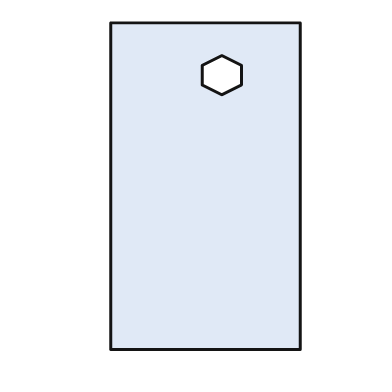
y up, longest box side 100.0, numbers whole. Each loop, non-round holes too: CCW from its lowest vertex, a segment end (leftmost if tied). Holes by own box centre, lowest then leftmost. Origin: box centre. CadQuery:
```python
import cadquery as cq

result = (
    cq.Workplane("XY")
    .moveTo(-29.0, -50.0)
    .lineTo(29.0, -50.0)
    .lineTo(29.0, 50.0)
    .lineTo(-29.0, 50.0)
    .close()
    .moveTo(5.0, 28.0)
    .lineTo(11.0, 31.0)
    .lineTo(11.0, 37.0)
    .lineTo(5.0, 40.0)
    .lineTo(-1.0, 37.0)
    .lineTo(-1.0, 31.0)
    .close()
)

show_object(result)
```